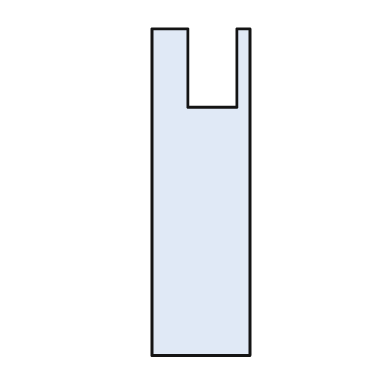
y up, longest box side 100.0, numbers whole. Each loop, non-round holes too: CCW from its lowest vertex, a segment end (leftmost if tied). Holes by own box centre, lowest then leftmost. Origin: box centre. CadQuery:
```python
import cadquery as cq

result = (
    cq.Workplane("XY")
    .moveTo(-15.0, -50.0)
    .lineTo(15.0, -50.0)
    .lineTo(15.0, 50.0)
    .lineTo(11.0, 50.0)
    .lineTo(11.0, 26.0)
    .lineTo(-4.0, 26.0)
    .lineTo(-4.0, 50.0)
    .lineTo(-15.0, 50.0)
    .close()
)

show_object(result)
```